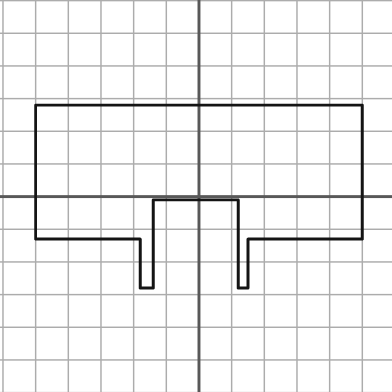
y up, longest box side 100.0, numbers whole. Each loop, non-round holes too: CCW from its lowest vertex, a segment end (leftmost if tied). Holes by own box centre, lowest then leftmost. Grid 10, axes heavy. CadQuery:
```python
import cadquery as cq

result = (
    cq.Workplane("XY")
    .moveTo(-18.0, -28.0)
    .lineTo(-14.0, -28.0)
    .lineTo(-14.0, -1.0)
    .lineTo(12.0, -1.0)
    .lineTo(12.0, -28.0)
    .lineTo(15.0, -28.0)
    .lineTo(15.0, -13.0)
    .lineTo(50.0, -13.0)
    .lineTo(50.0, 28.0)
    .lineTo(-50.0, 28.0)
    .lineTo(-50.0, -13.0)
    .lineTo(-18.0, -13.0)
    .close()
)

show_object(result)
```